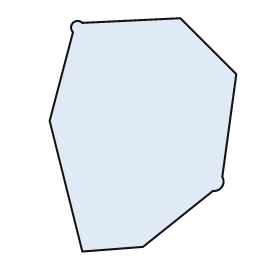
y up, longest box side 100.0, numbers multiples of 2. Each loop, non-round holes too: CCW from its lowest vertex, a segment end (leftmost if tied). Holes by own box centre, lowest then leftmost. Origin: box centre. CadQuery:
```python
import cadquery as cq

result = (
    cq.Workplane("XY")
    .moveTo(-26.0, -50.0)
    .lineTo(0.0, -48.0)
    .lineTo(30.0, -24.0)
    .threePointArc((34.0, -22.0), (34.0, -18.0))
    .lineTo(40.0, 26.0)
    .lineTo(16.0, 50.0)
    .lineTo(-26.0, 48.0)
    .threePointArc((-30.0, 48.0), (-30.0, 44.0))
    .lineTo(-40.0, 6.0)
    .close()
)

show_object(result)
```